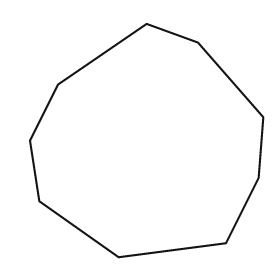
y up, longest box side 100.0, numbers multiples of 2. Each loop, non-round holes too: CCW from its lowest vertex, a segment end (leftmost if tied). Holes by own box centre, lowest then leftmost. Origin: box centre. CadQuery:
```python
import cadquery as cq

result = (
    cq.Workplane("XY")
    .moveTo(-12.0, -50.0)
    .lineTo(34.0, -44.0)
    .lineTo(48.0, -16.0)
    .lineTo(50.0, 10.0)
    .lineTo(22.0, 42.0)
    .lineTo(0.0, 50.0)
    .lineTo(-38.0, 24.0)
    .lineTo(-50.0, 0.0)
    .lineTo(-46.0, -26.0)
    .close()
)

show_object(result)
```